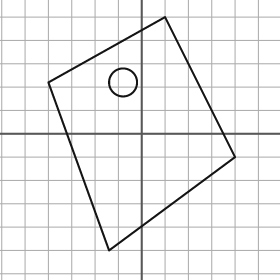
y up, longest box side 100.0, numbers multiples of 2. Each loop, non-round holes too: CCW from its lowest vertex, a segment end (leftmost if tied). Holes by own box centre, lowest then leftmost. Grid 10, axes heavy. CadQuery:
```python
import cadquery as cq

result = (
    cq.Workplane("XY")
    .moveTo(-14.0, -50.0)
    .lineTo(40.0, -10.0)
    .lineTo(10.0, 50.0)
    .lineTo(-40.0, 22.0)
    .close()
    .moveTo(-8.0, 22.0)
    .circle(6.0)
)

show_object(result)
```